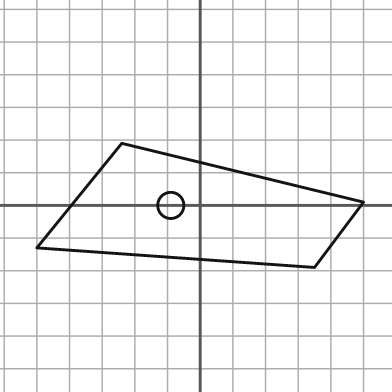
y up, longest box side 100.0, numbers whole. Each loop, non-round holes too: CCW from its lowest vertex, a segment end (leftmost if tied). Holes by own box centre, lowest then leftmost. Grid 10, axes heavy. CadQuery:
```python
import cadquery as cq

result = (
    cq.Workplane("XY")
    .moveTo(35.0, -19.0)
    .lineTo(50.0, 1.0)
    .lineTo(-24.0, 19.0)
    .lineTo(-50.0, -13.0)
    .close()
    .moveTo(-9.0, 0.0)
    .circle(4.0)
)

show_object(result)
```